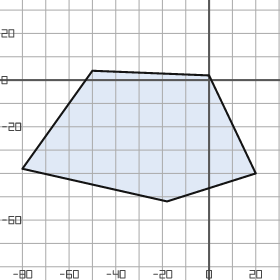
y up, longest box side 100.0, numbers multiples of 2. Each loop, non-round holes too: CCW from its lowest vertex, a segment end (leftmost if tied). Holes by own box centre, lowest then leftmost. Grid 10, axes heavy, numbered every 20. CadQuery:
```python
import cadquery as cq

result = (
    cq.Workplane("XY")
    .moveTo(-18.0, -52.0)
    .lineTo(20.0, -40.0)
    .lineTo(0.0, 2.0)
    .lineTo(-50.0, 4.0)
    .lineTo(-80.0, -38.0)
    .close()
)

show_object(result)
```